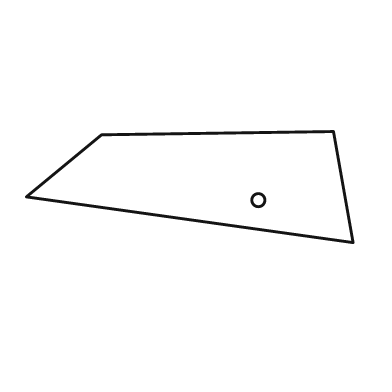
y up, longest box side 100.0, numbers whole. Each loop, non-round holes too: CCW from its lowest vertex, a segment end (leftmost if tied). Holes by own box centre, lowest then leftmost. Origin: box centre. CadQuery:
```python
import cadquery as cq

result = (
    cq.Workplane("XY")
    .moveTo(50.0, -17.0)
    .lineTo(44.0, 17.0)
    .lineTo(-27.0, 16.0)
    .lineTo(-50.0, -3.0)
    .close()
    .moveTo(21.0, -4.0)
    .circle(2.0)
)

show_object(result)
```